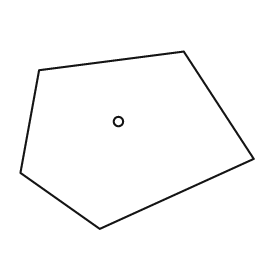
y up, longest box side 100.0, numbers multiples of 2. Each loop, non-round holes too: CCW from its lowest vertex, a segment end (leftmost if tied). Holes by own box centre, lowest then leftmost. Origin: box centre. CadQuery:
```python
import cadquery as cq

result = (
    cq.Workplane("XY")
    .moveTo(-16.0, -38.0)
    .lineTo(50.0, -8.0)
    .lineTo(20.0, 38.0)
    .lineTo(-42.0, 30.0)
    .lineTo(-50.0, -14.0)
    .close()
    .moveTo(-8.0, 8.0)
    .circle(2.0)
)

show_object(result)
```